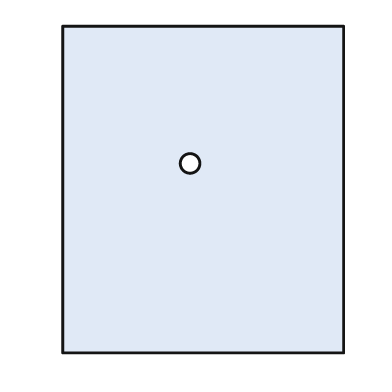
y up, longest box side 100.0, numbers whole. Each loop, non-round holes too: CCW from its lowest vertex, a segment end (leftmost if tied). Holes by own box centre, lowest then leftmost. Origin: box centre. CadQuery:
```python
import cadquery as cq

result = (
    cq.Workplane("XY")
    .moveTo(-43.0, -50.0)
    .lineTo(43.0, -50.0)
    .lineTo(43.0, 50.0)
    .lineTo(-43.0, 50.0)
    .close()
    .moveTo(-4.0, 8.0)
    .circle(3.0)
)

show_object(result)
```